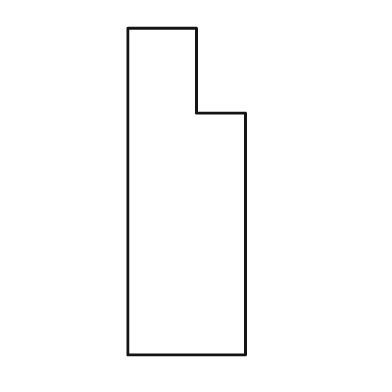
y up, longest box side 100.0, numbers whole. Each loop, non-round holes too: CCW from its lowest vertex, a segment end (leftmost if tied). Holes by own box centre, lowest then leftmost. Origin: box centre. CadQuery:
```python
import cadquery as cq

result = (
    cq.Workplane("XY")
    .moveTo(-18.0, -50.0)
    .lineTo(18.0, -50.0)
    .lineTo(18.0, 24.0)
    .lineTo(3.0, 24.0)
    .lineTo(3.0, 50.0)
    .lineTo(-18.0, 50.0)
    .close()
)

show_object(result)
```